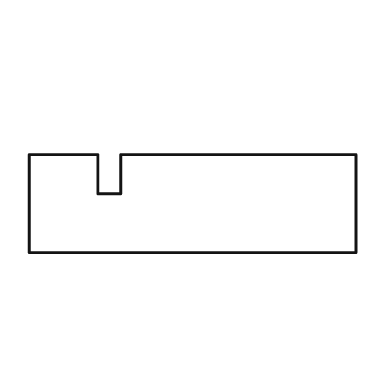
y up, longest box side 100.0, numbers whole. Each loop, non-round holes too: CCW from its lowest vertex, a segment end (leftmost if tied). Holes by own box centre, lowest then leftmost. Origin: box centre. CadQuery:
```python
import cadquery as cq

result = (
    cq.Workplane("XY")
    .moveTo(-50.0, -15.0)
    .lineTo(50.0, -15.0)
    .lineTo(50.0, 15.0)
    .lineTo(-22.0, 15.0)
    .lineTo(-22.0, 3.0)
    .lineTo(-29.0, 3.0)
    .lineTo(-29.0, 15.0)
    .lineTo(-50.0, 15.0)
    .close()
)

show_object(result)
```